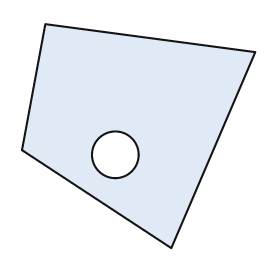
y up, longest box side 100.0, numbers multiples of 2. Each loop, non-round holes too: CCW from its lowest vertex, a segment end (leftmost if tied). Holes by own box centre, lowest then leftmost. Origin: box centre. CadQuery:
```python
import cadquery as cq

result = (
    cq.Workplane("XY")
    .moveTo(14.0, -48.0)
    .lineTo(50.0, 36.0)
    .lineTo(-40.0, 48.0)
    .lineTo(-50.0, -6.0)
    .close()
    .moveTo(-10.0, -8.0)
    .circle(10.0)
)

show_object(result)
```